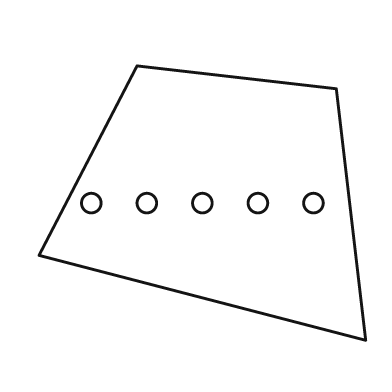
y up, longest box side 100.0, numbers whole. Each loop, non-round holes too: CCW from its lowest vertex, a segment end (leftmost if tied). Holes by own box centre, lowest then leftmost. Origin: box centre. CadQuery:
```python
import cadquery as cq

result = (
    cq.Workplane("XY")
    .moveTo(50.0, -42.0)
    .lineTo(41.0, 35.0)
    .lineTo(-20.0, 42.0)
    .lineTo(-50.0, -16.0)
    .close()
    .moveTo(-34.0, 0.0)
    .circle(3.0)
    .moveTo(-17.0, 0.0)
    .circle(3.0)
    .moveTo(0.0, 0.0)
    .circle(3.0)
    .moveTo(17.0, 0.0)
    .circle(3.0)
    .moveTo(34.0, 0.0)
    .circle(3.0)
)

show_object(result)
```